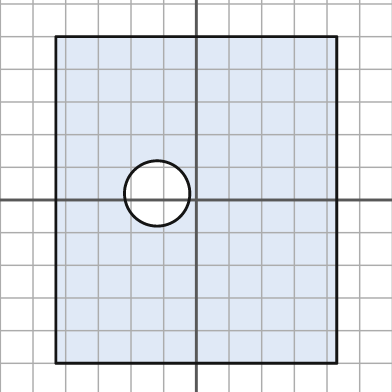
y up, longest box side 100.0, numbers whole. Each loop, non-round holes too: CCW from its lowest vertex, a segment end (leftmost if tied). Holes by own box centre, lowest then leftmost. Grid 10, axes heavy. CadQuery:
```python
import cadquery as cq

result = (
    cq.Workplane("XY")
    .moveTo(-43.0, -50.0)
    .lineTo(43.0, -50.0)
    .lineTo(43.0, 50.0)
    .lineTo(-43.0, 50.0)
    .close()
    .moveTo(-12.0, 2.0)
    .circle(10.0)
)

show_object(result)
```